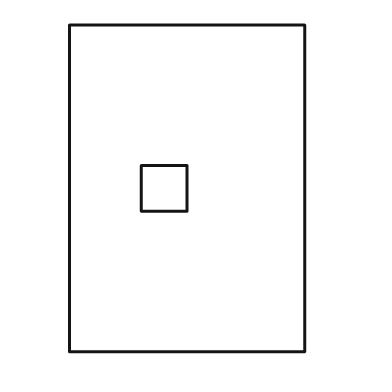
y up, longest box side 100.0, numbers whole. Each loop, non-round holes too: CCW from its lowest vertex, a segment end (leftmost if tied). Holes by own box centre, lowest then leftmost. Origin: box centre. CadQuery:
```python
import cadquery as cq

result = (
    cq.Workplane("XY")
    .moveTo(-36.0, -50.0)
    .lineTo(36.0, -50.0)
    .lineTo(36.0, 50.0)
    .lineTo(-36.0, 50.0)
    .close()
    .moveTo(-14.0, -7.0)
    .lineTo(0.0, -7.0)
    .lineTo(0.0, 7.0)
    .lineTo(-14.0, 7.0)
    .close()
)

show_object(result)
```